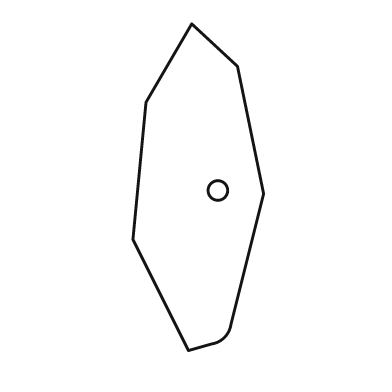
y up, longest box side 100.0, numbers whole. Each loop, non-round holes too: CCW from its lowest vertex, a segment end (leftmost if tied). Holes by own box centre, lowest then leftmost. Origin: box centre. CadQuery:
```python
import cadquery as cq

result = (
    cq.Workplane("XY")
    .moveTo(-3.0, -50.0)
    .lineTo(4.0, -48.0)
    .threePointArc((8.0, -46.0), (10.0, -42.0))
    .lineTo(20.0, -2.0)
    .lineTo(12.0, 37.0)
    .lineTo(-2.0, 50.0)
    .lineTo(-16.0, 26.0)
    .lineTo(-20.0, -16.0)
    .close()
    .moveTo(6.0, -1.0)
    .circle(3.0)
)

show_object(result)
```